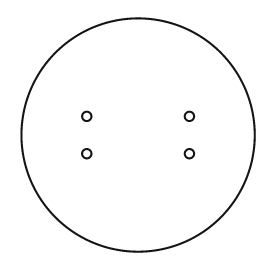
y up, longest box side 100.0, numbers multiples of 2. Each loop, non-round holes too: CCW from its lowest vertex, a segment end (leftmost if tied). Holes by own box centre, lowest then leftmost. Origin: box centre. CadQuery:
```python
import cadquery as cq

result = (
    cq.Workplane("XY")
    .moveTo(0.0, 0.0)
    .circle(50.0)
    .moveTo(-22.0, -8.0)
    .circle(2.0)
    .moveTo(22.0, -8.0)
    .circle(2.0)
    .moveTo(-22.0, 8.0)
    .circle(2.0)
    .moveTo(22.0, 8.0)
    .circle(2.0)
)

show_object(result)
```